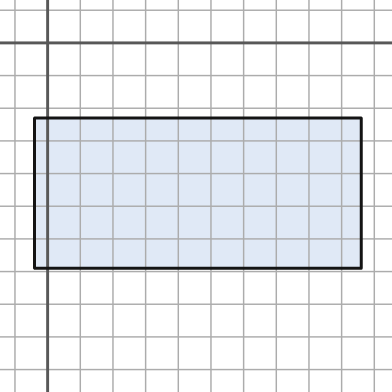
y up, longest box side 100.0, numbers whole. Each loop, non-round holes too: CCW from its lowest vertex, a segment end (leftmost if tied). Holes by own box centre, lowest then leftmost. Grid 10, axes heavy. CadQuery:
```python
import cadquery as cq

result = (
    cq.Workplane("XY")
    .moveTo(-4.0, -69.0)
    .lineTo(96.0, -69.0)
    .lineTo(96.0, -23.0)
    .lineTo(-4.0, -23.0)
    .close()
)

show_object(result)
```